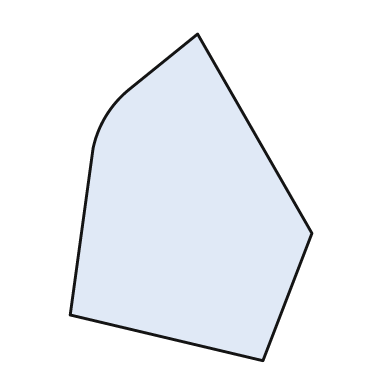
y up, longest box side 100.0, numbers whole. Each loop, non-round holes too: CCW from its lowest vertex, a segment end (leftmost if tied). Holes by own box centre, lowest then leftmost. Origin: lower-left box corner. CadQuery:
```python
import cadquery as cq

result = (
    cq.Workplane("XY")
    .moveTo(59.0, 0.0)
    .lineTo(74.0, 39.0)
    .lineTo(39.0, 100.0)
    .lineTo(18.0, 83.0)
    .threePointArc((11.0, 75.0), (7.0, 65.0))
    .lineTo(0.0, 14.0)
    .close()
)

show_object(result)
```